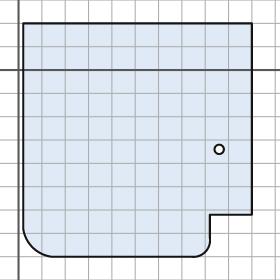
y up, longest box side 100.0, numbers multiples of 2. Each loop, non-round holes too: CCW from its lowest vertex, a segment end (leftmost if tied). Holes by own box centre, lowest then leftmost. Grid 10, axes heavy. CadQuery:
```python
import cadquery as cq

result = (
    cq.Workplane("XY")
    .moveTo(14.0, -80.0)
    .lineTo(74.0, -80.0)
    .threePointArc((80.0, -78.0), (82.0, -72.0))
    .lineTo(82.0, -62.0)
    .lineTo(100.0, -62.0)
    .lineTo(100.0, 20.0)
    .lineTo(2.0, 20.0)
    .lineTo(2.0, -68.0)
    .threePointArc((6.0, -76.0), (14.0, -80.0))
    .close()
    .moveTo(86.0, -34.0)
    .circle(2.0)
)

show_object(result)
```